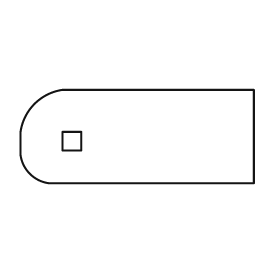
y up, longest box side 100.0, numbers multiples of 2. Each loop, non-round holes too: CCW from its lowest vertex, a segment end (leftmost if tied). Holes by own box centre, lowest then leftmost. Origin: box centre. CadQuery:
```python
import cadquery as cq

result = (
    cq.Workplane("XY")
    .moveTo(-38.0, -20.0)
    .lineTo(50.0, -20.0)
    .lineTo(50.0, 20.0)
    .lineTo(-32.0, 20.0)
    .threePointArc((-44.0, 14.0), (-50.0, 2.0))
    .lineTo(-50.0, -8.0)
    .threePointArc((-46.0, -16.0), (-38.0, -20.0))
    .close()
    .moveTo(-32.0, -6.0)
    .lineTo(-24.0, -6.0)
    .lineTo(-24.0, 2.0)
    .lineTo(-32.0, 2.0)
    .close()
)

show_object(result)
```